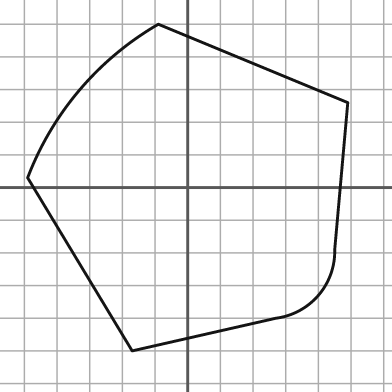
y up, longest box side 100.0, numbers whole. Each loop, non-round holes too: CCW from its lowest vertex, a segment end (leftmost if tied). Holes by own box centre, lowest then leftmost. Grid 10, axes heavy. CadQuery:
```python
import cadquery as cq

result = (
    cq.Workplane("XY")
    .moveTo(-17.0, -50.0)
    .lineTo(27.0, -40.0)
    .threePointArc((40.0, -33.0), (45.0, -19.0))
    .lineTo(49.0, 26.0)
    .lineTo(-9.0, 50.0)
    .threePointArc((-33.0, 30.0), (-49.0, 3.0))
    .close()
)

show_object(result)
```